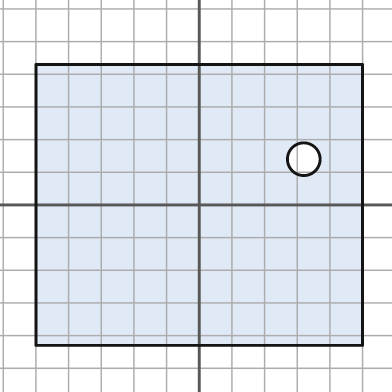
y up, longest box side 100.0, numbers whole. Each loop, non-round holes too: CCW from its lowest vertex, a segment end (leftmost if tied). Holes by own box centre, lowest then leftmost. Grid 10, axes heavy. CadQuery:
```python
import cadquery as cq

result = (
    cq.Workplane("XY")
    .moveTo(-50.0, -43.0)
    .lineTo(50.0, -43.0)
    .lineTo(50.0, 43.0)
    .lineTo(-50.0, 43.0)
    .close()
    .moveTo(32.0, 14.0)
    .circle(5.0)
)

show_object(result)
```